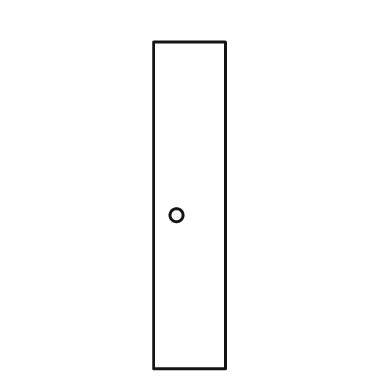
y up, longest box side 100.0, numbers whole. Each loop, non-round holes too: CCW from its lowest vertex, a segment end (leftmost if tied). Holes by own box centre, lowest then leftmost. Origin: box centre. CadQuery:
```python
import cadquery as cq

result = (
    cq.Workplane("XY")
    .moveTo(-11.0, -50.0)
    .lineTo(11.0, -50.0)
    .lineTo(11.0, 50.0)
    .lineTo(-11.0, 50.0)
    .close()
    .moveTo(-4.0, -3.0)
    .circle(2.0)
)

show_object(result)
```